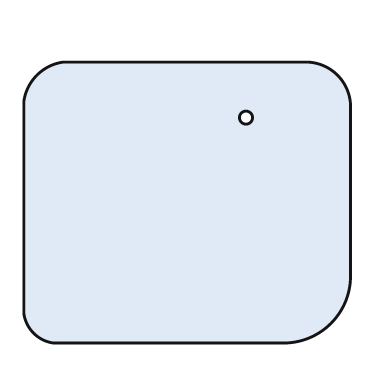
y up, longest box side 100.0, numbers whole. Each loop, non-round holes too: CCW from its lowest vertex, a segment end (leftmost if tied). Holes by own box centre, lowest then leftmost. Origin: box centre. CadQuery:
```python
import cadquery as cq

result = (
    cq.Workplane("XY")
    .moveTo(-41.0, -43.0)
    .lineTo(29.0, -43.0)
    .threePointArc((44.0, -37.0), (50.0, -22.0))
    .lineTo(50.0, 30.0)
    .threePointArc((46.0, 39.0), (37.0, 43.0))
    .lineTo(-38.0, 43.0)
    .threePointArc((-46.0, 39.0), (-50.0, 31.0))
    .lineTo(-50.0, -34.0)
    .threePointArc((-47.0, -40.0), (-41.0, -43.0))
    .close()
    .moveTo(18.0, 26.0)
    .circle(2.0)
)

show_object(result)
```